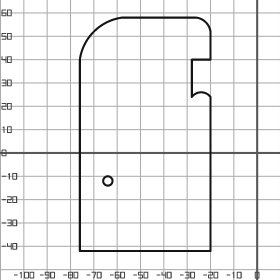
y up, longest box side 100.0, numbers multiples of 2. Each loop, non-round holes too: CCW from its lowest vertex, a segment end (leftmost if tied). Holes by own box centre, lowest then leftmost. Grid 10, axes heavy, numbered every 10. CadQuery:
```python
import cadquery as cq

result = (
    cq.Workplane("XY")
    .moveTo(-76.0, -42.0)
    .lineTo(-20.0, -42.0)
    .lineTo(-20.0, 24.0)
    .threePointArc((-24.0, 26.0), (-28.0, 24.0))
    .lineTo(-28.0, 40.0)
    .lineTo(-20.0, 40.0)
    .lineTo(-20.0, 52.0)
    .threePointArc((-22.0, 56.0), (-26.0, 58.0))
    .lineTo(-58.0, 58.0)
    .threePointArc((-70.0, 52.0), (-76.0, 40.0))
    .close()
    .moveTo(-64.0, -12.0)
    .circle(2.0)
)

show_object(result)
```